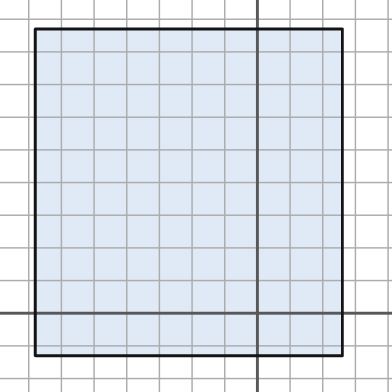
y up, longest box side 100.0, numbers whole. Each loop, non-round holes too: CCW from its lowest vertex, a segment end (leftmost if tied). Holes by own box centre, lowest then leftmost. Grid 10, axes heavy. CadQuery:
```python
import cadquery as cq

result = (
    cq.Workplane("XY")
    .moveTo(-68.0, -13.0)
    .lineTo(26.0, -13.0)
    .lineTo(26.0, 87.0)
    .lineTo(-68.0, 87.0)
    .close()
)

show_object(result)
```